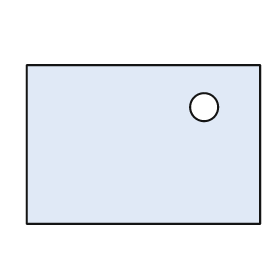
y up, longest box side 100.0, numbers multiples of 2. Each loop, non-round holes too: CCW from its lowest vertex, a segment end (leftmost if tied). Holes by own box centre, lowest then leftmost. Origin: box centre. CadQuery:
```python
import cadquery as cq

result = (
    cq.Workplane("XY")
    .moveTo(-50.0, -34.0)
    .lineTo(50.0, -34.0)
    .lineTo(50.0, 34.0)
    .lineTo(-50.0, 34.0)
    .close()
    .moveTo(26.0, 16.0)
    .circle(6.0)
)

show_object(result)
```